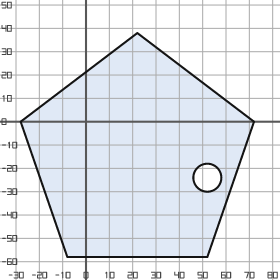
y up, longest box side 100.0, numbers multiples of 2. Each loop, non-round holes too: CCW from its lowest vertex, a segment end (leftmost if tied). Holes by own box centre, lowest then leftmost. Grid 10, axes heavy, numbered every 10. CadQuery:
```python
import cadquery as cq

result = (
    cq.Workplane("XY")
    .moveTo(-8.0, -58.0)
    .lineTo(52.0, -58.0)
    .lineTo(72.0, 0.0)
    .lineTo(22.0, 38.0)
    .lineTo(-28.0, 0.0)
    .close()
    .moveTo(52.0, -24.0)
    .circle(6.0)
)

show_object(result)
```